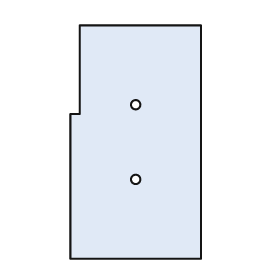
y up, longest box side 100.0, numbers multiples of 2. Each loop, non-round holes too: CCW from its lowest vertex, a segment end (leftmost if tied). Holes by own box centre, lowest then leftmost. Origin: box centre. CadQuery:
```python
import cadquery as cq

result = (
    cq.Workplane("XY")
    .moveTo(-28.0, -50.0)
    .lineTo(28.0, -50.0)
    .lineTo(28.0, 50.0)
    .lineTo(-24.0, 50.0)
    .lineTo(-24.0, 12.0)
    .lineTo(-28.0, 12.0)
    .close()
    .moveTo(0.0, -16.0)
    .circle(2.0)
    .moveTo(0.0, 16.0)
    .circle(2.0)
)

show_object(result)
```